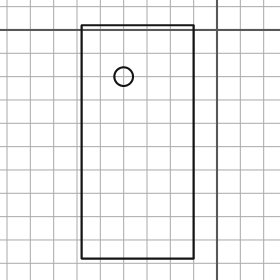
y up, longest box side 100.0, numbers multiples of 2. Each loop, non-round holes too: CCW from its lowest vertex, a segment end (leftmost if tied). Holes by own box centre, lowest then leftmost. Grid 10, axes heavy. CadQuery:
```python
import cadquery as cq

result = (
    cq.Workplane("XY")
    .moveTo(-58.0, -98.0)
    .lineTo(-10.0, -98.0)
    .lineTo(-10.0, 2.0)
    .lineTo(-58.0, 2.0)
    .close()
    .moveTo(-40.0, -20.0)
    .circle(4.0)
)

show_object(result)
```